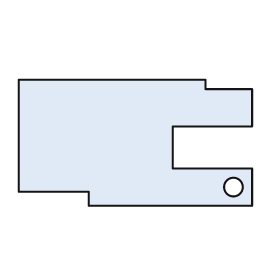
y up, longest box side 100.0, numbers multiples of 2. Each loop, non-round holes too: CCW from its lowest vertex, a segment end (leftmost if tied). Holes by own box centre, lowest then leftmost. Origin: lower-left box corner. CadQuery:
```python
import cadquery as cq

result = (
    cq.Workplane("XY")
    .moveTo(30.0, 0.0)
    .lineTo(100.0, 0.0)
    .lineTo(100.0, 16.0)
    .lineTo(66.0, 16.0)
    .lineTo(66.0, 34.0)
    .lineTo(100.0, 34.0)
    .lineTo(100.0, 50.0)
    .lineTo(80.0, 50.0)
    .lineTo(80.0, 54.0)
    .lineTo(0.0, 54.0)
    .lineTo(0.0, 6.0)
    .lineTo(30.0, 6.0)
    .close()
    .moveTo(92.0, 8.0)
    .circle(4.0)
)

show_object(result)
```